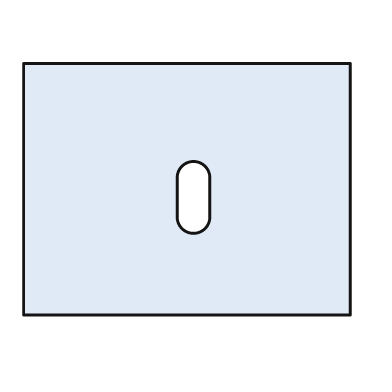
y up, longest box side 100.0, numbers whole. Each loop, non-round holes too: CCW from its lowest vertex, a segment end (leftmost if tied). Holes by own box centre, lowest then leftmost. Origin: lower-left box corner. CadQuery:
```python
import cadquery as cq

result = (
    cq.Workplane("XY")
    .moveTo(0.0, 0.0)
    .lineTo(100.0, 0.0)
    .lineTo(100.0, 77.0)
    .lineTo(0.0, 77.0)
    .close()
    .moveTo(47.0, 30.0)
    .threePointArc((52.0, 25.0), (57.0, 30.0))
    .lineTo(57.0, 42.0)
    .threePointArc((52.0, 47.0), (47.0, 42.0))
    .close()
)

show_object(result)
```